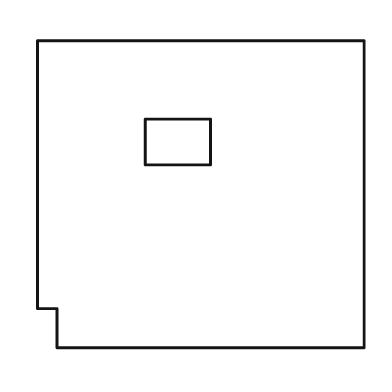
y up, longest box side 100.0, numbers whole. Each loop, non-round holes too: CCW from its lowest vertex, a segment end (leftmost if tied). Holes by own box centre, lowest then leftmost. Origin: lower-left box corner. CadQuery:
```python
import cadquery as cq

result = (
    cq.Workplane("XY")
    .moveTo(6.0, 0.0)
    .lineTo(100.0, 0.0)
    .lineTo(100.0, 94.0)
    .lineTo(0.0, 94.0)
    .lineTo(0.0, 12.0)
    .lineTo(6.0, 12.0)
    .close()
    .moveTo(33.0, 56.0)
    .lineTo(53.0, 56.0)
    .lineTo(53.0, 70.0)
    .lineTo(33.0, 70.0)
    .close()
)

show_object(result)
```